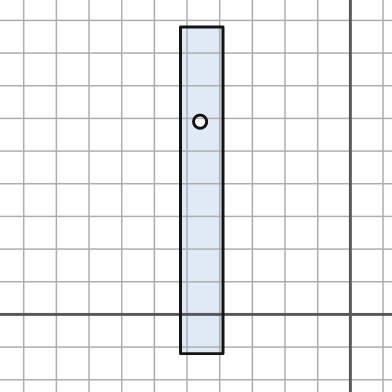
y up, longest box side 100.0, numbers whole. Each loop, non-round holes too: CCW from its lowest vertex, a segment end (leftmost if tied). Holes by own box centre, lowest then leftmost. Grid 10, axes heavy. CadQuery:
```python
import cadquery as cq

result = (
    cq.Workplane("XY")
    .moveTo(-52.0, -12.0)
    .lineTo(-39.0, -12.0)
    .lineTo(-39.0, 88.0)
    .lineTo(-52.0, 88.0)
    .close()
    .moveTo(-46.0, 59.0)
    .circle(2.0)
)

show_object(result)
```